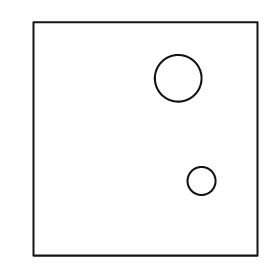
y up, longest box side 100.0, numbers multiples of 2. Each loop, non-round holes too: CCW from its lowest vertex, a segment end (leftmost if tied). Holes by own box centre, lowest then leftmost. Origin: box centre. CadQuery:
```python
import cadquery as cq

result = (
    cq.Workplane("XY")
    .moveTo(-48.0, -50.0)
    .lineTo(48.0, -50.0)
    .lineTo(48.0, 50.0)
    .lineTo(-48.0, 50.0)
    .close()
    .moveTo(24.0, -18.0)
    .circle(6.0)
    .moveTo(14.0, 26.0)
    .circle(10.0)
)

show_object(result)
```